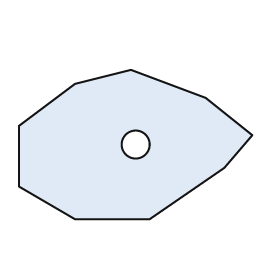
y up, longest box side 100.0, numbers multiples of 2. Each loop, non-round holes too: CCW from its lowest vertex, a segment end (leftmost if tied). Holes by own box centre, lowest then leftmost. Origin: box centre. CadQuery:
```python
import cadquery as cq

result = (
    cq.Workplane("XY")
    .moveTo(-26.0, -32.0)
    .lineTo(6.0, -32.0)
    .lineTo(38.0, -10.0)
    .lineTo(50.0, 4.0)
    .lineTo(30.0, 20.0)
    .lineTo(-2.0, 32.0)
    .lineTo(-26.0, 26.0)
    .lineTo(-50.0, 8.0)
    .lineTo(-50.0, -18.0)
    .close()
    .moveTo(0.0, 0.0)
    .circle(6.0)
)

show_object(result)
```